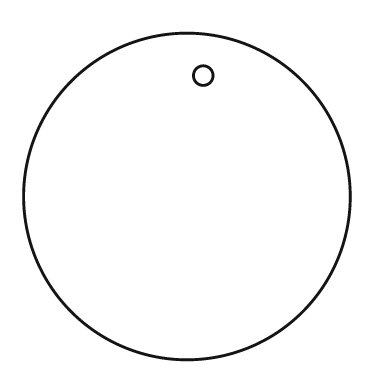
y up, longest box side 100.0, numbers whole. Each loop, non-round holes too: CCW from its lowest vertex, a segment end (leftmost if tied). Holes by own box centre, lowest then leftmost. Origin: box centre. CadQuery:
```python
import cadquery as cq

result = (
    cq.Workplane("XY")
    .moveTo(0.0, 0.0)
    .circle(50.0)
    .moveTo(5.0, 37.0)
    .circle(3.0)
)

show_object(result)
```